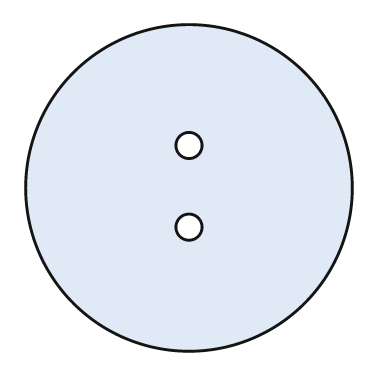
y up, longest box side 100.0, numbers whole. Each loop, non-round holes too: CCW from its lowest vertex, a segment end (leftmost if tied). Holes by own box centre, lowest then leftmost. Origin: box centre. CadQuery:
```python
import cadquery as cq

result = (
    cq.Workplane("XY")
    .moveTo(0.0, 0.0)
    .circle(50.0)
    .moveTo(0.0, -12.0)
    .circle(4.0)
    .moveTo(0.0, 13.0)
    .circle(4.0)
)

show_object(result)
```